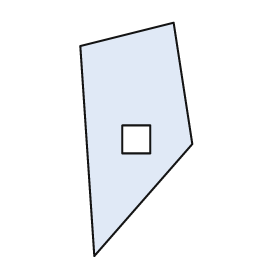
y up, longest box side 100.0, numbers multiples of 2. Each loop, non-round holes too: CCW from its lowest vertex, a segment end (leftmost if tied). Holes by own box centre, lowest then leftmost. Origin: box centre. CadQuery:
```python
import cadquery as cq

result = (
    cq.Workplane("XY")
    .moveTo(-18.0, -50.0)
    .lineTo(24.0, -2.0)
    .lineTo(16.0, 50.0)
    .lineTo(-24.0, 40.0)
    .close()
    .moveTo(-6.0, -6.0)
    .lineTo(6.0, -6.0)
    .lineTo(6.0, 6.0)
    .lineTo(-6.0, 6.0)
    .close()
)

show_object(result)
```